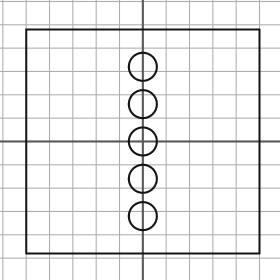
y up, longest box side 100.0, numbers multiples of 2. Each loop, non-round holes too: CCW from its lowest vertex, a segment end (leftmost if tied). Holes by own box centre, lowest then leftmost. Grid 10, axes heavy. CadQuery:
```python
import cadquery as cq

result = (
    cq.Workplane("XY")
    .moveTo(-50.0, -48.0)
    .lineTo(50.0, -48.0)
    .lineTo(50.0, 48.0)
    .lineTo(-50.0, 48.0)
    .close()
    .moveTo(0.0, -32.0)
    .circle(6.0)
    .moveTo(0.0, -16.0)
    .circle(6.0)
    .moveTo(0.0, 0.0)
    .circle(6.0)
    .moveTo(0.0, 16.0)
    .circle(6.0)
    .moveTo(0.0, 32.0)
    .circle(6.0)
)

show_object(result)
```